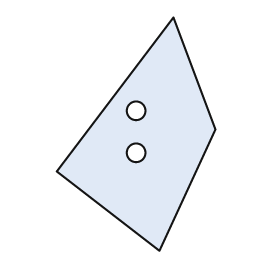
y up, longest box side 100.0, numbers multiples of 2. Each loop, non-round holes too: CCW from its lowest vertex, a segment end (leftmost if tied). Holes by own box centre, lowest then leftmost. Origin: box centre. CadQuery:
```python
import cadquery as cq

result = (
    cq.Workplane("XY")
    .moveTo(10.0, -50.0)
    .lineTo(34.0, 2.0)
    .lineTo(16.0, 50.0)
    .lineTo(-34.0, -16.0)
    .close()
    .moveTo(0.0, -8.0)
    .circle(4.0)
    .moveTo(0.0, 10.0)
    .circle(4.0)
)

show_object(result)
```